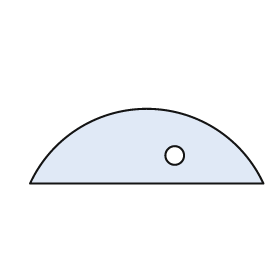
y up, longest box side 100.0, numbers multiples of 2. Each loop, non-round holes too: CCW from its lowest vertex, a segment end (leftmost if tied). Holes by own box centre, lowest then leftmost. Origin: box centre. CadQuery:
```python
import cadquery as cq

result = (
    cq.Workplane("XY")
    .moveTo(-50.0, -16.0)
    .lineTo(50.0, -16.0)
    .threePointArc((0.0, 16.0), (-50.0, -16.0))
    .close()
    .moveTo(12.0, -4.0)
    .circle(4.0)
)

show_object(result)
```